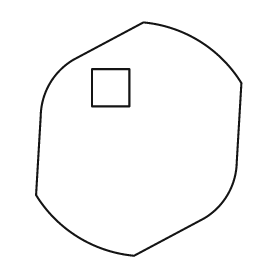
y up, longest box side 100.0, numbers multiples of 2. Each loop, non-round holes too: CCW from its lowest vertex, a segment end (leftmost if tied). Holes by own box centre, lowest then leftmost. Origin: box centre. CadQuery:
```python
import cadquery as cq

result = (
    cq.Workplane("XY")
    .moveTo(-2.0, -50.0)
    .lineTo(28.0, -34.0)
    .threePointArc((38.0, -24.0), (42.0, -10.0))
    .lineTo(44.0, 24.0)
    .threePointArc((26.0, 42.0), (2.0, 50.0))
    .lineTo(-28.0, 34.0)
    .threePointArc((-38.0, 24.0), (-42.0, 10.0))
    .lineTo(-44.0, -24.0)
    .threePointArc((-26.0, -42.0), (-2.0, -50.0))
    .close()
    .moveTo(-20.0, 14.0)
    .lineTo(-4.0, 14.0)
    .lineTo(-4.0, 30.0)
    .lineTo(-20.0, 30.0)
    .close()
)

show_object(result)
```